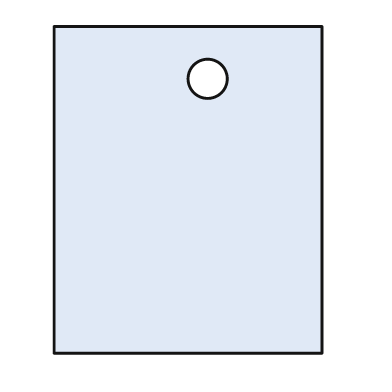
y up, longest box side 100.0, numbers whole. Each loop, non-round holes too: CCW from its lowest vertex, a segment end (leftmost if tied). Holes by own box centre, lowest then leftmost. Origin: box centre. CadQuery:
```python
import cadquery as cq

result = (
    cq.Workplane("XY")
    .moveTo(-41.0, -50.0)
    .lineTo(41.0, -50.0)
    .lineTo(41.0, 50.0)
    .lineTo(-41.0, 50.0)
    .close()
    .moveTo(6.0, 34.0)
    .circle(6.0)
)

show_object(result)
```